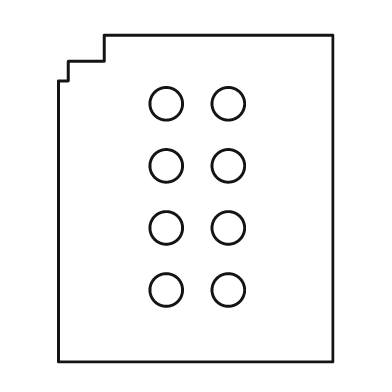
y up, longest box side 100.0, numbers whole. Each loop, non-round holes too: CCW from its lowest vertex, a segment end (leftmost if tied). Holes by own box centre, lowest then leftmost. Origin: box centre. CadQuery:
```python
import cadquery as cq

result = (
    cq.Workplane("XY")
    .moveTo(-42.0, -50.0)
    .lineTo(42.0, -50.0)
    .lineTo(42.0, 50.0)
    .lineTo(-28.0, 50.0)
    .lineTo(-28.0, 42.0)
    .lineTo(-39.0, 42.0)
    .lineTo(-39.0, 36.0)
    .lineTo(-42.0, 36.0)
    .close()
    .moveTo(-9.0, -28.0)
    .circle(5.0)
    .moveTo(10.0, -28.0)
    .circle(5.0)
    .moveTo(-9.0, -9.0)
    .circle(5.0)
    .moveTo(10.0, -9.0)
    .circle(5.0)
    .moveTo(-9.0, 10.0)
    .circle(5.0)
    .moveTo(10.0, 10.0)
    .circle(5.0)
    .moveTo(-9.0, 29.0)
    .circle(5.0)
    .moveTo(10.0, 29.0)
    .circle(5.0)
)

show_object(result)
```